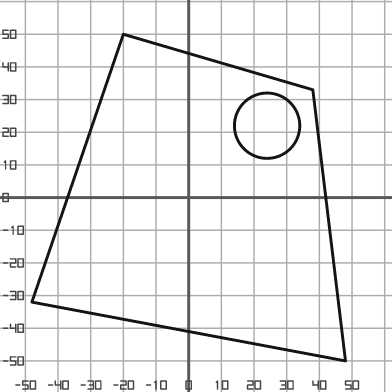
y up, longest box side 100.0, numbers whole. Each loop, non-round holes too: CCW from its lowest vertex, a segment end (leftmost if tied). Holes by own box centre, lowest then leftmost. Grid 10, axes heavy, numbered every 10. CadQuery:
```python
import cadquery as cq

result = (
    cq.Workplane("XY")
    .moveTo(48.0, -50.0)
    .lineTo(38.0, 33.0)
    .lineTo(-20.0, 50.0)
    .lineTo(-48.0, -32.0)
    .close()
    .moveTo(24.0, 22.0)
    .circle(10.0)
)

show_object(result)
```